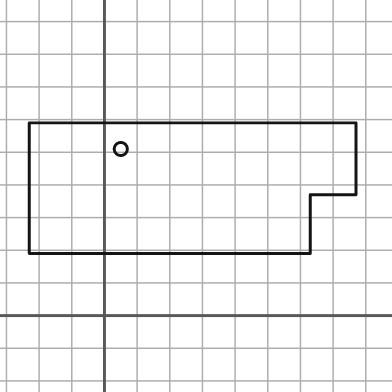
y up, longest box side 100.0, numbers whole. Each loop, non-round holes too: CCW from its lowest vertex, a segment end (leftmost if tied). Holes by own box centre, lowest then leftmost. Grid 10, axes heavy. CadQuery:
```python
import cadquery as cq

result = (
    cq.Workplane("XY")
    .moveTo(-23.0, 19.0)
    .lineTo(63.0, 19.0)
    .lineTo(63.0, 37.0)
    .lineTo(77.0, 37.0)
    .lineTo(77.0, 59.0)
    .lineTo(-23.0, 59.0)
    .close()
    .moveTo(5.0, 51.0)
    .circle(2.0)
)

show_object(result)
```